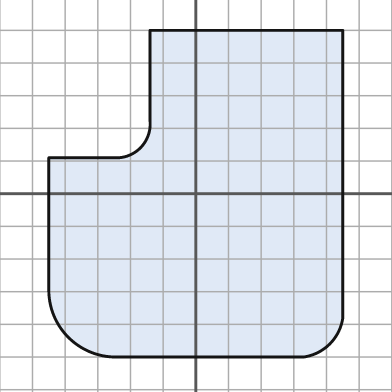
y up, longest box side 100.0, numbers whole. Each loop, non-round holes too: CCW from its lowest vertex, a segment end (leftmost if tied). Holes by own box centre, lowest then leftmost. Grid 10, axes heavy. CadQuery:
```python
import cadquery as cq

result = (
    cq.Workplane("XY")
    .moveTo(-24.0, -50.0)
    .lineTo(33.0, -50.0)
    .threePointArc((41.0, -46.0), (45.0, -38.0))
    .lineTo(45.0, 50.0)
    .lineTo(-14.0, 50.0)
    .lineTo(-14.0, 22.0)
    .threePointArc((-17.0, 14.0), (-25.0, 11.0))
    .lineTo(-45.0, 11.0)
    .lineTo(-45.0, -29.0)
    .threePointArc((-39.0, -44.0), (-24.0, -50.0))
    .close()
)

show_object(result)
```